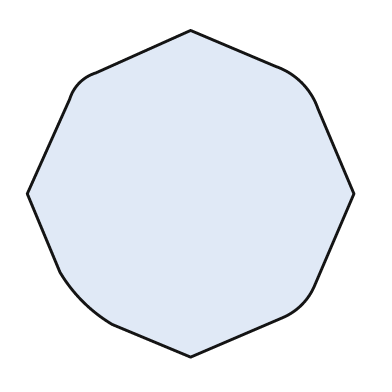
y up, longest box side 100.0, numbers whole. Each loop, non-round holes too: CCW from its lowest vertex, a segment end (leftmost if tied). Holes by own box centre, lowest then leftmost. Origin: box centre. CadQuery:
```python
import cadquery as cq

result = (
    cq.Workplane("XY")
    .moveTo(0.0, -50.0)
    .lineTo(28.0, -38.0)
    .threePointArc((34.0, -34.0), (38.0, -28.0))
    .lineTo(50.0, 0.0)
    .lineTo(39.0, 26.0)
    .threePointArc((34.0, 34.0), (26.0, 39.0))
    .lineTo(0.0, 50.0)
    .lineTo(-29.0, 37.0)
    .threePointArc((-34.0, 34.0), (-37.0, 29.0))
    .lineTo(-50.0, 0.0)
    .lineTo(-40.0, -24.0)
    .threePointArc((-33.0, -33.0), (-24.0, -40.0))
    .close()
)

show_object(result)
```